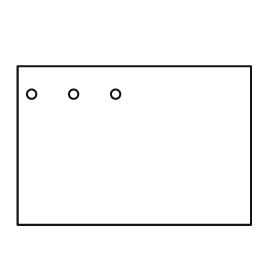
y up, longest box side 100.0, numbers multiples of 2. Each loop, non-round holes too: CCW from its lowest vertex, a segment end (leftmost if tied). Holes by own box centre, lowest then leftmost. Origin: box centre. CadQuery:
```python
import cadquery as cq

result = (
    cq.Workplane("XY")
    .moveTo(-50.0, -34.0)
    .lineTo(50.0, -34.0)
    .lineTo(50.0, 34.0)
    .lineTo(-50.0, 34.0)
    .close()
    .moveTo(-44.0, 22.0)
    .circle(2.0)
    .moveTo(-26.0, 22.0)
    .circle(2.0)
    .moveTo(-8.0, 22.0)
    .circle(2.0)
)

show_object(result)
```